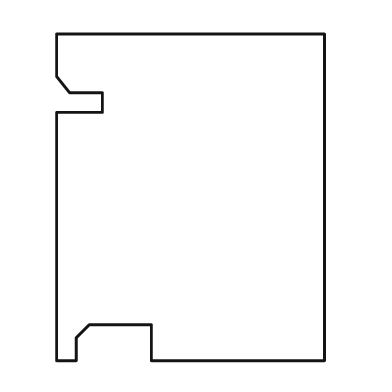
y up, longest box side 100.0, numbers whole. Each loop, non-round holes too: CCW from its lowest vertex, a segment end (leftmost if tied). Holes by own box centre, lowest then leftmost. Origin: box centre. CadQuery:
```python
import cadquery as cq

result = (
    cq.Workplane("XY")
    .moveTo(-41.0, -50.0)
    .lineTo(-35.0, -50.0)
    .lineTo(-35.0, -43.0)
    .lineTo(-31.0, -39.0)
    .lineTo(-12.0, -39.0)
    .lineTo(-12.0, -50.0)
    .lineTo(41.0, -50.0)
    .lineTo(41.0, 50.0)
    .lineTo(-41.0, 50.0)
    .lineTo(-41.0, 37.0)
    .lineTo(-37.0, 32.0)
    .lineTo(-27.0, 32.0)
    .lineTo(-27.0, 26.0)
    .lineTo(-41.0, 26.0)
    .close()
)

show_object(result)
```